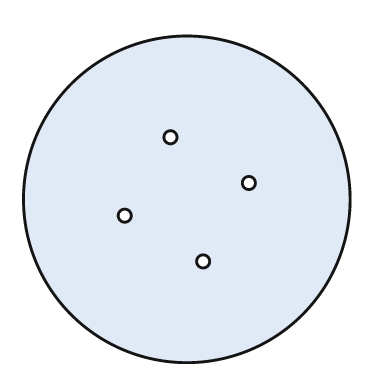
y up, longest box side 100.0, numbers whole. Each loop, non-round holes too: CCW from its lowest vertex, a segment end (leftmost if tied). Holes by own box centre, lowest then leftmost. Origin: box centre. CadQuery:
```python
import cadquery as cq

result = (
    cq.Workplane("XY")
    .moveTo(0.0, 0.0)
    .circle(50.0)
    .moveTo(5.0, -19.0)
    .circle(2.0)
    .moveTo(-19.0, -5.0)
    .circle(2.0)
    .moveTo(19.0, 5.0)
    .circle(2.0)
    .moveTo(-5.0, 19.0)
    .circle(2.0)
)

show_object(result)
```